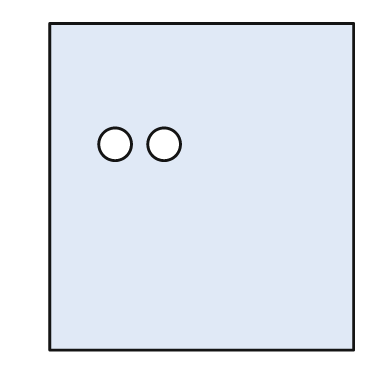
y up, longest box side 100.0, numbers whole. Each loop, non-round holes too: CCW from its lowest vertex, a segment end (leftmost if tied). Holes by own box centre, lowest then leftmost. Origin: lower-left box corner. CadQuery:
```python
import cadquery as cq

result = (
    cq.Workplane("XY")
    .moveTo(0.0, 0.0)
    .lineTo(93.0, 0.0)
    .lineTo(93.0, 100.0)
    .lineTo(0.0, 100.0)
    .close()
    .moveTo(20.0, 63.0)
    .circle(5.0)
    .moveTo(35.0, 63.0)
    .circle(5.0)
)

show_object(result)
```